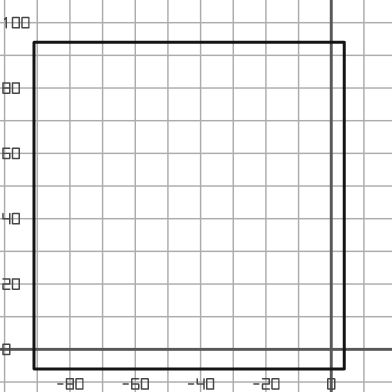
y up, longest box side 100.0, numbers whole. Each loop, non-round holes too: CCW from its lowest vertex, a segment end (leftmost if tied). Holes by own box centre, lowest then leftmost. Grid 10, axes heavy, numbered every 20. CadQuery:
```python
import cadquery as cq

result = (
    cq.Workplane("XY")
    .moveTo(-91.0, -6.0)
    .lineTo(4.0, -6.0)
    .lineTo(4.0, 94.0)
    .lineTo(-91.0, 94.0)
    .close()
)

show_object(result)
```